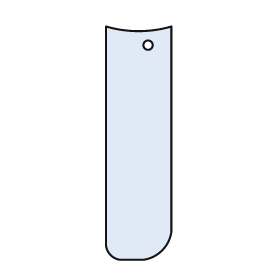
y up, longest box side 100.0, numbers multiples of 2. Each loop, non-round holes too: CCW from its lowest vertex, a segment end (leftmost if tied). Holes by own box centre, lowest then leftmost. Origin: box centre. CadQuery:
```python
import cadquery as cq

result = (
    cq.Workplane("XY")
    .moveTo(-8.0, -50.0)
    .lineTo(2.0, -50.0)
    .threePointArc((10.0, -46.0), (14.0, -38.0))
    .lineTo(14.0, 50.0)
    .threePointArc((0.0, 48.0), (-14.0, 50.0))
    .lineTo(-14.0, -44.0)
    .threePointArc((-12.0, -48.0), (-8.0, -50.0))
    .close()
    .moveTo(4.0, 42.0)
    .circle(2.0)
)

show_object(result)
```